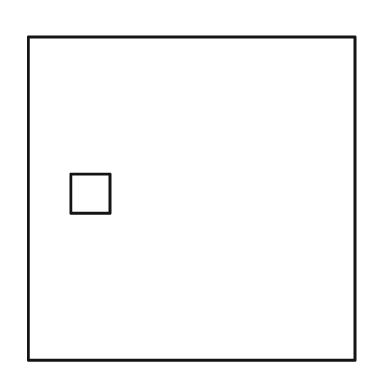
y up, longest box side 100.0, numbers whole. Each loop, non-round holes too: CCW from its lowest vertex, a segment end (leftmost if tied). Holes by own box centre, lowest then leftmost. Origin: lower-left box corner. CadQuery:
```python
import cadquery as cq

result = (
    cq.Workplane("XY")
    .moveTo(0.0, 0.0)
    .lineTo(100.0, 0.0)
    .lineTo(100.0, 99.0)
    .lineTo(0.0, 99.0)
    .close()
    .moveTo(13.0, 45.0)
    .lineTo(25.0, 45.0)
    .lineTo(25.0, 57.0)
    .lineTo(13.0, 57.0)
    .close()
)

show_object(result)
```